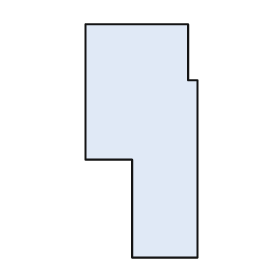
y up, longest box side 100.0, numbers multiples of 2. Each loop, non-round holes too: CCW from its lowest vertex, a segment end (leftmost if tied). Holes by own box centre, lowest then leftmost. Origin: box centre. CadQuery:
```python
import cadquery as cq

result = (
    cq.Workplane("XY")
    .moveTo(-4.0, -50.0)
    .lineTo(24.0, -50.0)
    .lineTo(24.0, 26.0)
    .lineTo(20.0, 26.0)
    .lineTo(20.0, 50.0)
    .lineTo(-24.0, 50.0)
    .lineTo(-24.0, -8.0)
    .lineTo(-4.0, -8.0)
    .close()
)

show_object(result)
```